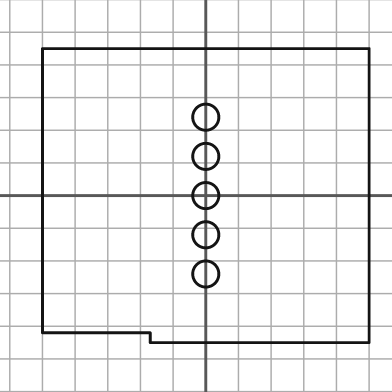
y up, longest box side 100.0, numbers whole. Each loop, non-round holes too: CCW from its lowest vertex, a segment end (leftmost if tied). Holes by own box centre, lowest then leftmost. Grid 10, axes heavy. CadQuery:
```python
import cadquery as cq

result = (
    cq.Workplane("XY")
    .moveTo(-17.0, -45.0)
    .lineTo(50.0, -45.0)
    .lineTo(50.0, 45.0)
    .lineTo(-50.0, 45.0)
    .lineTo(-50.0, -42.0)
    .lineTo(-17.0, -42.0)
    .close()
    .moveTo(0.0, -24.0)
    .circle(4.0)
    .moveTo(0.0, -12.0)
    .circle(4.0)
    .moveTo(0.0, 0.0)
    .circle(4.0)
    .moveTo(0.0, 12.0)
    .circle(4.0)
    .moveTo(0.0, 24.0)
    .circle(4.0)
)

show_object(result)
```